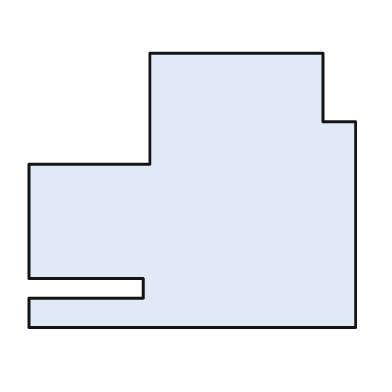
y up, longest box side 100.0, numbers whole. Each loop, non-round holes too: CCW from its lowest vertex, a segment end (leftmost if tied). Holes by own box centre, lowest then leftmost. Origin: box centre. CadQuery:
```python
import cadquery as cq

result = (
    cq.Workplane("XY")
    .moveTo(-50.0, -42.0)
    .lineTo(50.0, -42.0)
    .lineTo(50.0, 21.0)
    .lineTo(40.0, 21.0)
    .lineTo(40.0, 42.0)
    .lineTo(-13.0, 42.0)
    .lineTo(-13.0, 8.0)
    .lineTo(-50.0, 8.0)
    .lineTo(-50.0, -27.0)
    .lineTo(-15.0, -27.0)
    .lineTo(-15.0, -33.0)
    .lineTo(-50.0, -33.0)
    .close()
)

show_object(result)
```